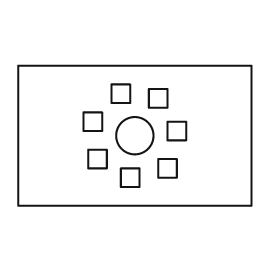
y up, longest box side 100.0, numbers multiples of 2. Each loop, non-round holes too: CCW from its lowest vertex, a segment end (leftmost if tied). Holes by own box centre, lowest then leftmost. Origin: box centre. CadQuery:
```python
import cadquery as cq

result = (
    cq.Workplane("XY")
    .moveTo(-50.0, -30.0)
    .lineTo(50.0, -30.0)
    .lineTo(50.0, 30.0)
    .lineTo(-50.0, 30.0)
    .close()
    .moveTo(-6.0, -22.0)
    .lineTo(2.0, -22.0)
    .lineTo(2.0, -14.0)
    .lineTo(-6.0, -14.0)
    .close()
    .moveTo(10.0, -18.0)
    .lineTo(18.0, -18.0)
    .lineTo(18.0, -10.0)
    .lineTo(10.0, -10.0)
    .close()
    .moveTo(-20.0, -14.0)
    .lineTo(-12.0, -14.0)
    .lineTo(-12.0, -6.0)
    .lineTo(-20.0, -6.0)
    .close()
    .moveTo(0.0, 0.0)
    .circle(8.0)
    .moveTo(14.0, -2.0)
    .lineTo(22.0, -2.0)
    .lineTo(22.0, 6.0)
    .lineTo(14.0, 6.0)
    .close()
    .moveTo(-22.0, 2.0)
    .lineTo(-14.0, 2.0)
    .lineTo(-14.0, 10.0)
    .lineTo(-22.0, 10.0)
    .close()
    .moveTo(6.0, 12.0)
    .lineTo(14.0, 12.0)
    .lineTo(14.0, 20.0)
    .lineTo(6.0, 20.0)
    .close()
    .moveTo(-10.0, 14.0)
    .lineTo(-2.0, 14.0)
    .lineTo(-2.0, 22.0)
    .lineTo(-10.0, 22.0)
    .close()
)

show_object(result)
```